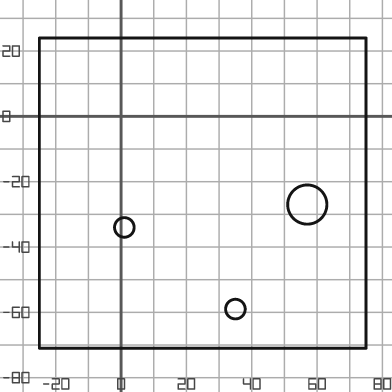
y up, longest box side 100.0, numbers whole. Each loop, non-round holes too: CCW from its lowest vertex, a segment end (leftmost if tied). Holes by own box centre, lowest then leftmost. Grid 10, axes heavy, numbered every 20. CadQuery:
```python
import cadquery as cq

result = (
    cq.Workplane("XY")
    .moveTo(-25.0, -71.0)
    .lineTo(75.0, -71.0)
    .lineTo(75.0, 24.0)
    .lineTo(-25.0, 24.0)
    .close()
    .moveTo(35.0, -59.0)
    .circle(3.0)
    .moveTo(1.0, -34.0)
    .circle(3.0)
    .moveTo(57.0, -27.0)
    .circle(6.0)
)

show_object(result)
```